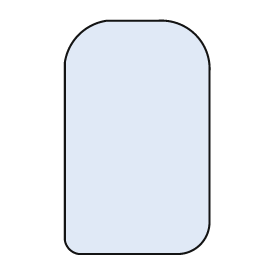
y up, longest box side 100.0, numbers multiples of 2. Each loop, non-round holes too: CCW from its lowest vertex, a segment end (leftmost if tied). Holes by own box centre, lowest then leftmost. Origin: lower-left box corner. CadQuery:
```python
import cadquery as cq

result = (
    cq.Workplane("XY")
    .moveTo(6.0, 0.0)
    .lineTo(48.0, 0.0)
    .threePointArc((58.0, 4.0), (62.0, 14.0))
    .lineTo(62.0, 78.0)
    .threePointArc((56.0, 94.0), (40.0, 100.0))
    .lineTo(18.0, 100.0)
    .threePointArc((6.0, 94.0), (0.0, 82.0))
    .lineTo(0.0, 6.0)
    .threePointArc((2.0, 2.0), (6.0, 0.0))
    .close()
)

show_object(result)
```